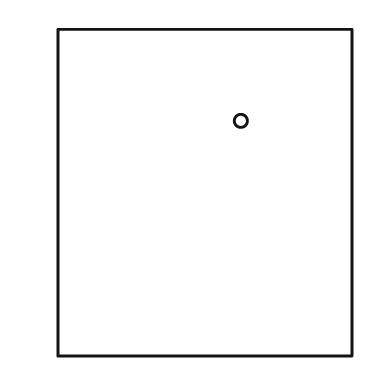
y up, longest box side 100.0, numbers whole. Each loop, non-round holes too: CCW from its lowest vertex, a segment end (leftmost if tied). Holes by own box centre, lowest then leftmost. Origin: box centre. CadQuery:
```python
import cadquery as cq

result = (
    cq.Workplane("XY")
    .moveTo(-45.0, -50.0)
    .lineTo(45.0, -50.0)
    .lineTo(45.0, 50.0)
    .lineTo(-45.0, 50.0)
    .close()
    .moveTo(11.0, 22.0)
    .circle(2.0)
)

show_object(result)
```